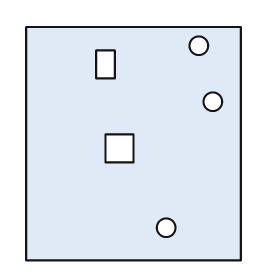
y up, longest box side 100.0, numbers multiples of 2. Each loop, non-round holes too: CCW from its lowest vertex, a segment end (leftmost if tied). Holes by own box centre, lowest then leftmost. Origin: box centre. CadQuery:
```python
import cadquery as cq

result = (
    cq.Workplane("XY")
    .moveTo(-46.0, -50.0)
    .lineTo(46.0, -50.0)
    .lineTo(46.0, 50.0)
    .lineTo(-46.0, 50.0)
    .close()
    .moveTo(14.0, -36.0)
    .circle(4.0)
    .moveTo(-12.0, -8.0)
    .lineTo(0.0, -8.0)
    .lineTo(0.0, 4.0)
    .lineTo(-12.0, 4.0)
    .close()
    .moveTo(34.0, 18.0)
    .circle(4.0)
    .moveTo(-16.0, 28.0)
    .lineTo(-8.0, 28.0)
    .lineTo(-8.0, 40.0)
    .lineTo(-16.0, 40.0)
    .close()
    .moveTo(28.0, 42.0)
    .circle(4.0)
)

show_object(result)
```